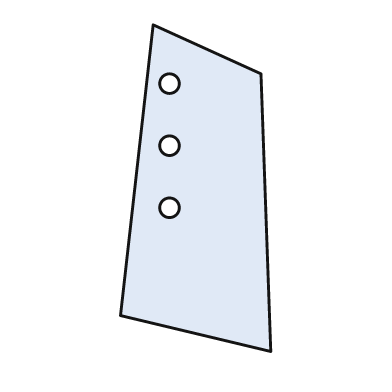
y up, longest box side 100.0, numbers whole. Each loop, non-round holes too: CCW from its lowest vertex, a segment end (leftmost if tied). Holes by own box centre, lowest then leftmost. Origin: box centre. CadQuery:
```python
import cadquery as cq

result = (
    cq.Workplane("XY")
    .moveTo(23.0, -50.0)
    .lineTo(20.0, 35.0)
    .lineTo(-13.0, 50.0)
    .lineTo(-23.0, -39.0)
    .close()
    .moveTo(-8.0, -6.0)
    .circle(3.0)
    .moveTo(-8.0, 13.0)
    .circle(3.0)
    .moveTo(-8.0, 32.0)
    .circle(3.0)
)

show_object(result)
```